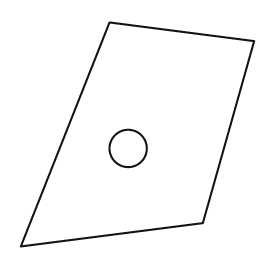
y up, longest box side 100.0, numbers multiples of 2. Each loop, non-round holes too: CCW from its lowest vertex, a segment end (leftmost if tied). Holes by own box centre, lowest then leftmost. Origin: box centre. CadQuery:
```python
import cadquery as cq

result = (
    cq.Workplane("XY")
    .moveTo(-50.0, -48.0)
    .lineTo(28.0, -38.0)
    .lineTo(50.0, 40.0)
    .lineTo(-12.0, 48.0)
    .close()
    .moveTo(-4.0, -6.0)
    .circle(8.0)
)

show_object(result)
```